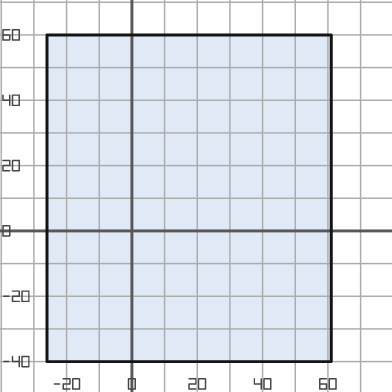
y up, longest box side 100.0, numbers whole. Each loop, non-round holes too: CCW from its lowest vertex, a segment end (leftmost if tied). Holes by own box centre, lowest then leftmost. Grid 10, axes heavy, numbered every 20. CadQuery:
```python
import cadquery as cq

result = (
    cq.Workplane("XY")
    .moveTo(-26.0, -40.0)
    .lineTo(61.0, -40.0)
    .lineTo(61.0, 60.0)
    .lineTo(-26.0, 60.0)
    .close()
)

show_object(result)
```